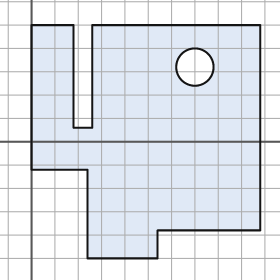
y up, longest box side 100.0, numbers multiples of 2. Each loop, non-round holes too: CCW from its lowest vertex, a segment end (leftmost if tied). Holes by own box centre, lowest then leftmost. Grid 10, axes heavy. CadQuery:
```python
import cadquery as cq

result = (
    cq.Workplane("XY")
    .moveTo(24.0, -50.0)
    .lineTo(54.0, -50.0)
    .lineTo(54.0, -38.0)
    .lineTo(98.0, -38.0)
    .lineTo(98.0, 50.0)
    .lineTo(26.0, 50.0)
    .lineTo(26.0, 6.0)
    .lineTo(18.0, 6.0)
    .lineTo(18.0, 50.0)
    .lineTo(0.0, 50.0)
    .lineTo(0.0, -12.0)
    .lineTo(24.0, -12.0)
    .close()
    .moveTo(70.0, 32.0)
    .circle(8.0)
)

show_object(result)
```